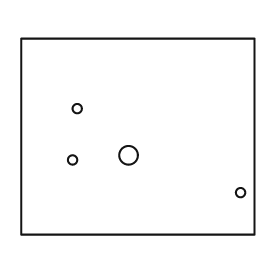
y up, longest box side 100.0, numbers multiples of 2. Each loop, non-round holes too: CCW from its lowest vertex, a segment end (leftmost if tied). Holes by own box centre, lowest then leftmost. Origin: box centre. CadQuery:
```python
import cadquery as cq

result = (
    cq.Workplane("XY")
    .moveTo(-50.0, -42.0)
    .lineTo(50.0, -42.0)
    .lineTo(50.0, 42.0)
    .lineTo(-50.0, 42.0)
    .close()
    .moveTo(44.0, -24.0)
    .circle(2.0)
    .moveTo(-28.0, -10.0)
    .circle(2.0)
    .moveTo(-4.0, -8.0)
    .circle(4.0)
    .moveTo(-26.0, 12.0)
    .circle(2.0)
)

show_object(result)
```